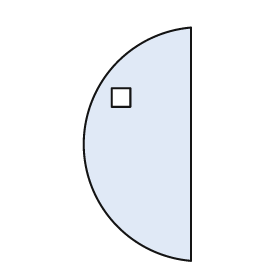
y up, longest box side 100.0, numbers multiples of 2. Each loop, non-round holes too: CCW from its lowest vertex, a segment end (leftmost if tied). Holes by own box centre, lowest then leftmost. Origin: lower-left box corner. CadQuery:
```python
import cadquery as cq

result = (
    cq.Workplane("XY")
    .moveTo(46.0, 0.0)
    .lineTo(46.0, 100.0)
    .threePointArc((0.0, 50.0), (46.0, 0.0))
    .close()
    .moveTo(12.0, 66.0)
    .lineTo(20.0, 66.0)
    .lineTo(20.0, 74.0)
    .lineTo(12.0, 74.0)
    .close()
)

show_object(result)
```